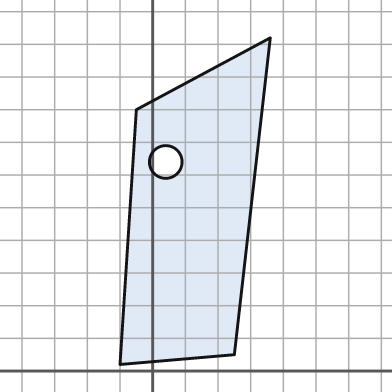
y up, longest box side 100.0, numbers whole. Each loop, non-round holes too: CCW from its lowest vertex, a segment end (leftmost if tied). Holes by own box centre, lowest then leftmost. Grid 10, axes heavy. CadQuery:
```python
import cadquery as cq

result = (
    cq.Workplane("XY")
    .moveTo(-10.0, 2.0)
    .lineTo(25.0, 5.0)
    .lineTo(36.0, 102.0)
    .lineTo(-5.0, 80.0)
    .close()
    .moveTo(4.0, 64.0)
    .circle(5.0)
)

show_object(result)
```